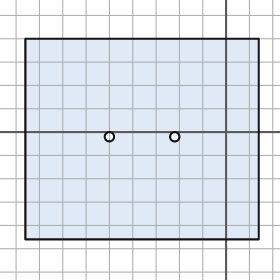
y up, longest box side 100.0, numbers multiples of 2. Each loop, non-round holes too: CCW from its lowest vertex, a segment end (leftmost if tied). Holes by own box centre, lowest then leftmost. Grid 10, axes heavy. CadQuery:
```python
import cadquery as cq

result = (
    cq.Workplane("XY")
    .moveTo(-86.0, -46.0)
    .lineTo(14.0, -46.0)
    .lineTo(14.0, 40.0)
    .lineTo(-86.0, 40.0)
    .close()
    .moveTo(-50.0, -2.0)
    .circle(2.0)
    .moveTo(-22.0, -2.0)
    .circle(2.0)
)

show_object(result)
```